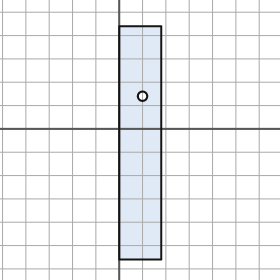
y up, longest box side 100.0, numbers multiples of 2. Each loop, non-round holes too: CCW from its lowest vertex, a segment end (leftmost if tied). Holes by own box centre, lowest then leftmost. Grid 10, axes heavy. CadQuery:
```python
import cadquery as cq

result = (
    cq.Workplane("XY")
    .moveTo(0.0, -56.0)
    .lineTo(18.0, -56.0)
    .lineTo(18.0, 44.0)
    .lineTo(0.0, 44.0)
    .close()
    .moveTo(10.0, 14.0)
    .circle(2.0)
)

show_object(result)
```